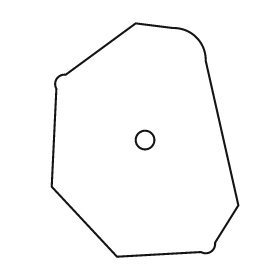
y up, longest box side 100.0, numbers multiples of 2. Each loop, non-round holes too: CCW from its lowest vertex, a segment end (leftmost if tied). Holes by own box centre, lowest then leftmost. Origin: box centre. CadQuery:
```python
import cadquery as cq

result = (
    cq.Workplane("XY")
    .moveTo(-12.0, -50.0)
    .lineTo(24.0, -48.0)
    .threePointArc((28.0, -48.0), (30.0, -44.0))
    .lineTo(40.0, -28.0)
    .lineTo(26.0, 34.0)
    .threePointArc((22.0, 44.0), (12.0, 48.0))
    .lineTo(-4.0, 50.0)
    .lineTo(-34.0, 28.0)
    .threePointArc((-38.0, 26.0), (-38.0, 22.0))
    .lineTo(-40.0, -20.0)
    .close()
    .moveTo(0.0, 0.0)
    .circle(4.0)
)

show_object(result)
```